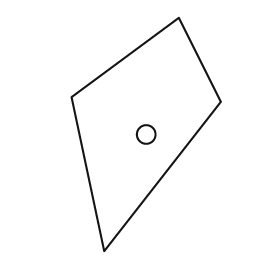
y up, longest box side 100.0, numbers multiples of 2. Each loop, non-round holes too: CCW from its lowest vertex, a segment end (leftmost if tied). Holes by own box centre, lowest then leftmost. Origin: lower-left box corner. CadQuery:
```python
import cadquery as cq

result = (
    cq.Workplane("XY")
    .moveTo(14.0, 0.0)
    .lineTo(64.0, 64.0)
    .lineTo(46.0, 100.0)
    .lineTo(0.0, 66.0)
    .close()
    .moveTo(32.0, 50.0)
    .circle(4.0)
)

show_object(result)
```